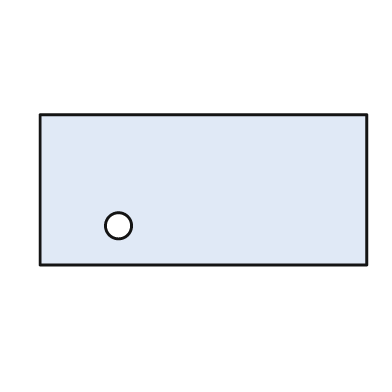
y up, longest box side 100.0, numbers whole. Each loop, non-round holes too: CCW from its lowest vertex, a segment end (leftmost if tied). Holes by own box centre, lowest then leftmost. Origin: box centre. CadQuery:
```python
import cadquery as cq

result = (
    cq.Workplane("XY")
    .moveTo(-50.0, -23.0)
    .lineTo(50.0, -23.0)
    .lineTo(50.0, 23.0)
    .lineTo(-50.0, 23.0)
    .close()
    .moveTo(-26.0, -11.0)
    .circle(4.0)
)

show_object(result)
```